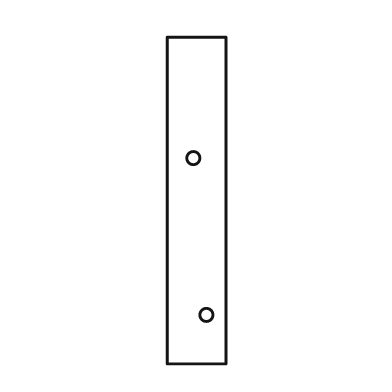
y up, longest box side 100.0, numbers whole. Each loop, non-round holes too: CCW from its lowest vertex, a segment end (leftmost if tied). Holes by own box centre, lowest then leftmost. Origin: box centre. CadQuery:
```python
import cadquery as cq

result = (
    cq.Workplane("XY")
    .moveTo(-9.0, -50.0)
    .lineTo(9.0, -50.0)
    .lineTo(9.0, 50.0)
    .lineTo(-9.0, 50.0)
    .close()
    .moveTo(3.0, -35.0)
    .circle(2.0)
    .moveTo(-1.0, 13.0)
    .circle(2.0)
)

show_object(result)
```